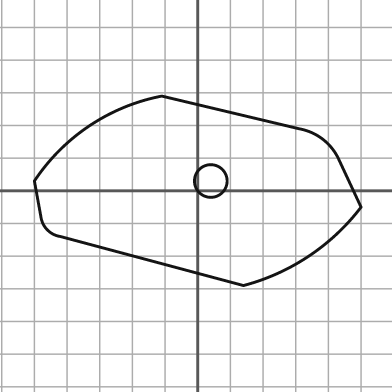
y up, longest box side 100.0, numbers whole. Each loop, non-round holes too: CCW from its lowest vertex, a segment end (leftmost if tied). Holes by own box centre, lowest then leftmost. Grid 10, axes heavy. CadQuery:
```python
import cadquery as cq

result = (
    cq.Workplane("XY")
    .moveTo(14.0, -29.0)
    .threePointArc((34.0, -20.0), (50.0, -5.0))
    .lineTo(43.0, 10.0)
    .threePointArc((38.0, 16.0), (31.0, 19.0))
    .lineTo(-11.0, 29.0)
    .threePointArc((-33.0, 20.0), (-50.0, 3.0))
    .lineTo(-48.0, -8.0)
    .threePointArc((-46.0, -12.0), (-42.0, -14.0))
    .close()
    .moveTo(4.0, 3.0)
    .circle(5.0)
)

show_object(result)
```